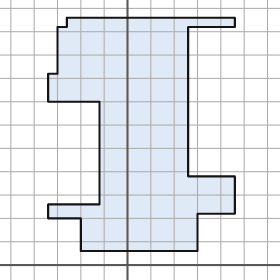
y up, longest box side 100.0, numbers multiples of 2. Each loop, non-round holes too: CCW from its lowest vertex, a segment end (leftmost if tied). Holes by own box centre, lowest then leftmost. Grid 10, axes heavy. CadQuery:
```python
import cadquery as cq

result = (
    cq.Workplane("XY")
    .moveTo(-20.0, 6.0)
    .lineTo(30.0, 6.0)
    .lineTo(30.0, 22.0)
    .lineTo(46.0, 22.0)
    .lineTo(46.0, 38.0)
    .lineTo(26.0, 38.0)
    .lineTo(26.0, 102.0)
    .lineTo(46.0, 102.0)
    .lineTo(46.0, 106.0)
    .lineTo(-26.0, 106.0)
    .lineTo(-26.0, 102.0)
    .lineTo(-30.0, 102.0)
    .lineTo(-30.0, 82.0)
    .lineTo(-34.0, 82.0)
    .lineTo(-34.0, 70.0)
    .lineTo(-12.0, 70.0)
    .lineTo(-12.0, 26.0)
    .lineTo(-34.0, 26.0)
    .lineTo(-34.0, 20.0)
    .lineTo(-20.0, 20.0)
    .close()
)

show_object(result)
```